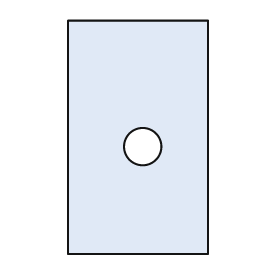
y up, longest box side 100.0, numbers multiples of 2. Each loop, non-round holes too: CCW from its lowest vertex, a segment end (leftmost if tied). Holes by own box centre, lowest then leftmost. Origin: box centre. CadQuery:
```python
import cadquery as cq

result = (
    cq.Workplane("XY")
    .moveTo(-30.0, -50.0)
    .lineTo(30.0, -50.0)
    .lineTo(30.0, 50.0)
    .lineTo(-30.0, 50.0)
    .close()
    .moveTo(2.0, -4.0)
    .circle(8.0)
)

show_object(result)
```